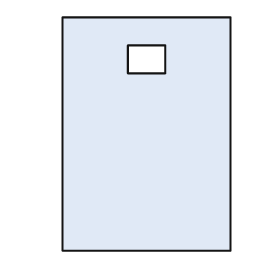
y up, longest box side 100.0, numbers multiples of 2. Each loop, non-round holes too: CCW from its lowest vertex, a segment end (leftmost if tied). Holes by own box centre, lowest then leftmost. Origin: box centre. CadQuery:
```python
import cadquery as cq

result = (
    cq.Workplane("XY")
    .moveTo(-36.0, -50.0)
    .lineTo(36.0, -50.0)
    .lineTo(36.0, 50.0)
    .lineTo(-36.0, 50.0)
    .close()
    .moveTo(-8.0, 26.0)
    .lineTo(8.0, 26.0)
    .lineTo(8.0, 38.0)
    .lineTo(-8.0, 38.0)
    .close()
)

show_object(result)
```